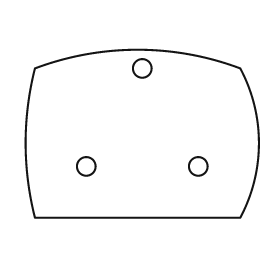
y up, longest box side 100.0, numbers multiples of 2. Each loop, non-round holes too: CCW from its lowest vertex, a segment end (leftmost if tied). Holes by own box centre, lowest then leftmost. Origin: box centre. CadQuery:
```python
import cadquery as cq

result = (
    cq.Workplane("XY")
    .moveTo(-46.0, -36.0)
    .lineTo(42.0, -36.0)
    .threePointArc((50.0, -4.0), (42.0, 28.0))
    .threePointArc((-2.0, 36.0), (-46.0, 28.0))
    .threePointArc((-50.0, -4.0), (-46.0, -36.0))
    .close()
    .moveTo(-24.0, -14.0)
    .circle(4.0)
    .moveTo(24.0, -14.0)
    .circle(4.0)
    .moveTo(0.0, 28.0)
    .circle(4.0)
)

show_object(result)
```